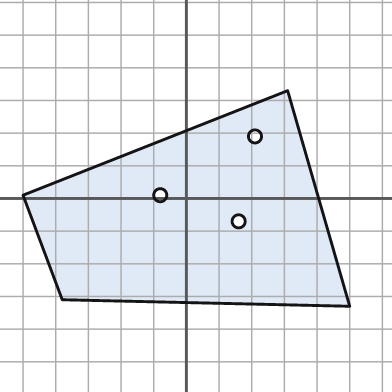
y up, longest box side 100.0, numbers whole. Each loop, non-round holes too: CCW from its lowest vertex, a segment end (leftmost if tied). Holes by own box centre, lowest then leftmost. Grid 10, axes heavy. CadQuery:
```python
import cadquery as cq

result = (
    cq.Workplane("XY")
    .moveTo(50.0, -33.0)
    .lineTo(31.0, 33.0)
    .lineTo(-50.0, 1.0)
    .lineTo(-38.0, -31.0)
    .close()
    .moveTo(16.0, -7.0)
    .circle(2.0)
    .moveTo(-8.0, 1.0)
    .circle(2.0)
    .moveTo(21.0, 19.0)
    .circle(2.0)
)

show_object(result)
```